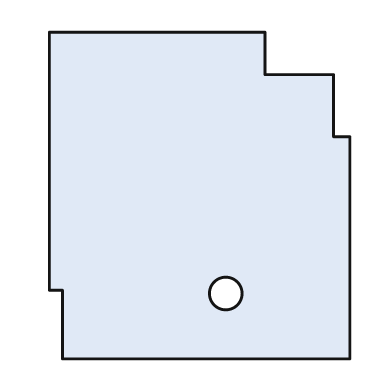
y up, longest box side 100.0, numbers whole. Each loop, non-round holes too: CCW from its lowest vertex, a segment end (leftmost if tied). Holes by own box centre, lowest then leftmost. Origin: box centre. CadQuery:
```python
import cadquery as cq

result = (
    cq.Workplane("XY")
    .moveTo(-42.0, -50.0)
    .lineTo(46.0, -50.0)
    .lineTo(46.0, 18.0)
    .lineTo(41.0, 18.0)
    .lineTo(41.0, 37.0)
    .lineTo(20.0, 37.0)
    .lineTo(20.0, 50.0)
    .lineTo(-46.0, 50.0)
    .lineTo(-46.0, -29.0)
    .lineTo(-42.0, -29.0)
    .close()
    .moveTo(8.0, -30.0)
    .circle(5.0)
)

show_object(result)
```